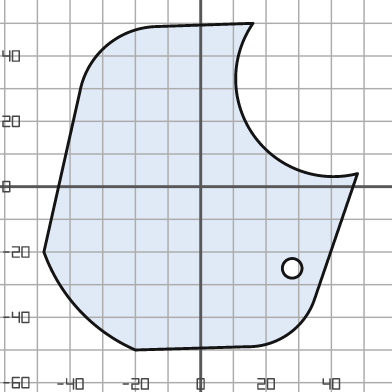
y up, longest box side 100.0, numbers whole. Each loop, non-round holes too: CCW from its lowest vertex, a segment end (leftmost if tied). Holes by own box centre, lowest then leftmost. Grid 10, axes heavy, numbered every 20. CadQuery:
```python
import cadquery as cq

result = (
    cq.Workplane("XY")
    .moveTo(-20.0, -50.0)
    .lineTo(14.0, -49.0)
    .threePointArc((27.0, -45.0), (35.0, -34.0))
    .lineTo(48.0, 4.0)
    .threePointArc((16.0, 16.0), (16.0, 50.0))
    .lineTo(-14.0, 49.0)
    .threePointArc((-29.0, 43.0), (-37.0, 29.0))
    .lineTo(-48.0, -20.0)
    .threePointArc((-37.0, -38.0), (-20.0, -50.0))
    .close()
    .moveTo(28.0, -25.0)
    .circle(3.0)
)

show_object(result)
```